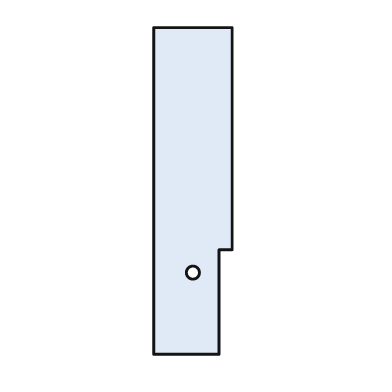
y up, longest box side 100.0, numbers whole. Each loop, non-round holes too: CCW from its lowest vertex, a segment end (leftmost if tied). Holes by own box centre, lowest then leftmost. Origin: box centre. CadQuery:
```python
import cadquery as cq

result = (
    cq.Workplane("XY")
    .moveTo(-12.0, -50.0)
    .lineTo(8.0, -50.0)
    .lineTo(8.0, -18.0)
    .lineTo(12.0, -18.0)
    .lineTo(12.0, 50.0)
    .lineTo(-12.0, 50.0)
    .close()
    .moveTo(0.0, -25.0)
    .circle(2.0)
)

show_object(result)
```